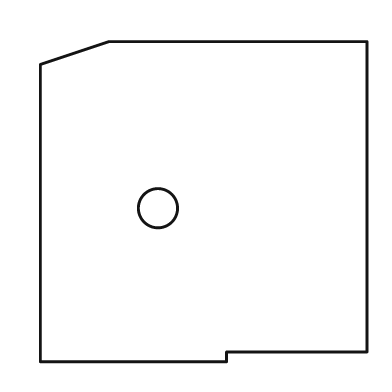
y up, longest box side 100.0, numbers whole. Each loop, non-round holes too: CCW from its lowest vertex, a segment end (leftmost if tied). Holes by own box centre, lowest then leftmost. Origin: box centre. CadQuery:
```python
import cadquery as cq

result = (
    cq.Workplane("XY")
    .moveTo(-50.0, -49.0)
    .lineTo(7.0, -49.0)
    .lineTo(7.0, -46.0)
    .lineTo(50.0, -46.0)
    .lineTo(50.0, 49.0)
    .lineTo(-29.0, 49.0)
    .lineTo(-50.0, 42.0)
    .close()
    .moveTo(-14.0, -2.0)
    .circle(6.0)
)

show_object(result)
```